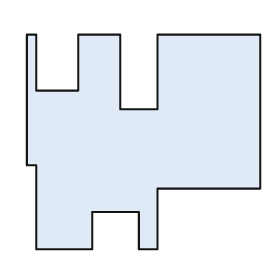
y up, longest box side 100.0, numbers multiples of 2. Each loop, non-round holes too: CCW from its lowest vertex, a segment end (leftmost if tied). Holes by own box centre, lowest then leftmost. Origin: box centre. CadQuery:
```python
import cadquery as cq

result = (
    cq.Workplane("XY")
    .moveTo(-46.0, -46.0)
    .lineTo(-22.0, -46.0)
    .lineTo(-22.0, -30.0)
    .lineTo(-2.0, -30.0)
    .lineTo(-2.0, -46.0)
    .lineTo(6.0, -46.0)
    .lineTo(6.0, -20.0)
    .lineTo(50.0, -20.0)
    .lineTo(50.0, 46.0)
    .lineTo(6.0, 46.0)
    .lineTo(6.0, 14.0)
    .lineTo(-10.0, 14.0)
    .lineTo(-10.0, 46.0)
    .lineTo(-28.0, 46.0)
    .lineTo(-28.0, 22.0)
    .lineTo(-46.0, 22.0)
    .lineTo(-46.0, 46.0)
    .lineTo(-50.0, 46.0)
    .lineTo(-50.0, -10.0)
    .lineTo(-46.0, -10.0)
    .close()
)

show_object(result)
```